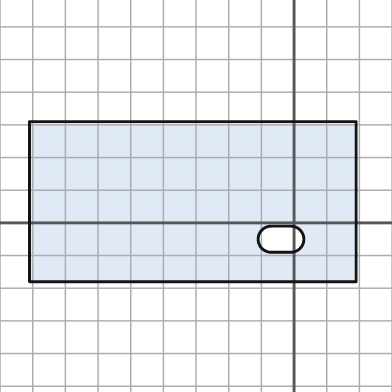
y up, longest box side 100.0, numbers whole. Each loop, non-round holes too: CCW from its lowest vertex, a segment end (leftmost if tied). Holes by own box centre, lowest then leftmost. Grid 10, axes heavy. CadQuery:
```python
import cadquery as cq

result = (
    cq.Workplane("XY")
    .moveTo(-81.0, -18.0)
    .lineTo(19.0, -18.0)
    .lineTo(19.0, 31.0)
    .lineTo(-81.0, 31.0)
    .close()
    .moveTo(-7.0, -9.0)
    .lineTo(-1.0, -9.0)
    .threePointArc((3.0, -5.0), (-1.0, -1.0))
    .lineTo(-7.0, -1.0)
    .threePointArc((-11.0, -5.0), (-7.0, -9.0))
    .close()
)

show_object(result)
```